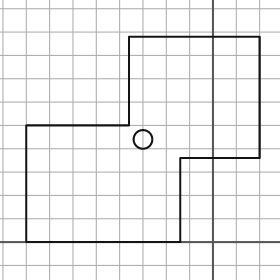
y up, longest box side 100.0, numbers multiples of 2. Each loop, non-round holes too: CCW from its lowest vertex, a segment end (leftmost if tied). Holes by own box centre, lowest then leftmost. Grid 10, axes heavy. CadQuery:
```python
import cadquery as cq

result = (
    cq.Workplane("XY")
    .moveTo(-80.0, 0.0)
    .lineTo(-14.0, 0.0)
    .lineTo(-14.0, 36.0)
    .lineTo(20.0, 36.0)
    .lineTo(20.0, 88.0)
    .lineTo(-36.0, 88.0)
    .lineTo(-36.0, 50.0)
    .lineTo(-80.0, 50.0)
    .close()
    .moveTo(-30.0, 44.0)
    .circle(4.0)
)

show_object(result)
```